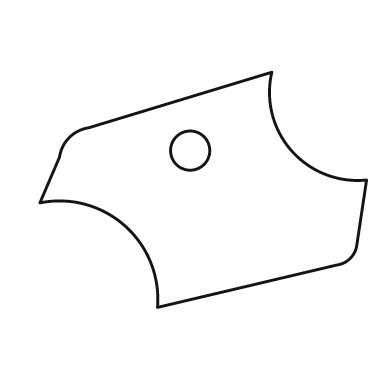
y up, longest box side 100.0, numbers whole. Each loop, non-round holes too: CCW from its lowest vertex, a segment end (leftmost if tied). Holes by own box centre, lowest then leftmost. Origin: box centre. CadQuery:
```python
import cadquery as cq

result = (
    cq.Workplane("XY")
    .moveTo(-14.0, -36.0)
    .lineTo(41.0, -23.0)
    .threePointArc((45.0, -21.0), (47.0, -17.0))
    .lineTo(50.0, 3.0)
    .threePointArc((27.0, 12.0), (21.0, 36.0))
    .lineTo(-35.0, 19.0)
    .threePointArc((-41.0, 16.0), (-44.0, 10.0))
    .lineTo(-50.0, -4.0)
    .threePointArc((-24.0, -11.0), (-14.0, -36.0))
    .close()
    .moveTo(-4.0, 12.0)
    .circle(6.0)
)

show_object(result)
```